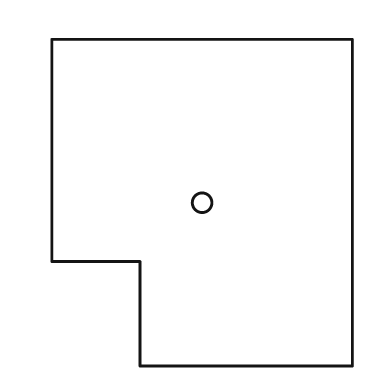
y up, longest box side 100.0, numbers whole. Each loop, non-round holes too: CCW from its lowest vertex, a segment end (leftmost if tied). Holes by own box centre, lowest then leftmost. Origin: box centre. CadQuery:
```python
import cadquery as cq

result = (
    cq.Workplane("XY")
    .moveTo(-19.0, -50.0)
    .lineTo(46.0, -50.0)
    .lineTo(46.0, 50.0)
    .lineTo(-46.0, 50.0)
    .lineTo(-46.0, -18.0)
    .lineTo(-19.0, -18.0)
    .close()
    .moveTo(0.0, 0.0)
    .circle(3.0)
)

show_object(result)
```